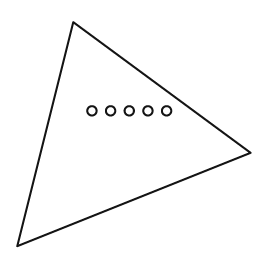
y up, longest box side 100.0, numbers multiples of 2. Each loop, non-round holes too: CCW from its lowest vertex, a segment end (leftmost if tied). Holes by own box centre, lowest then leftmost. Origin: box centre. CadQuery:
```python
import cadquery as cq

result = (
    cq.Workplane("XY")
    .moveTo(-50.0, -48.0)
    .lineTo(50.0, -8.0)
    .lineTo(-26.0, 48.0)
    .close()
    .moveTo(-18.0, 10.0)
    .circle(2.0)
    .moveTo(-10.0, 10.0)
    .circle(2.0)
    .moveTo(-2.0, 10.0)
    .circle(2.0)
    .moveTo(6.0, 10.0)
    .circle(2.0)
    .moveTo(14.0, 10.0)
    .circle(2.0)
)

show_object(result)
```